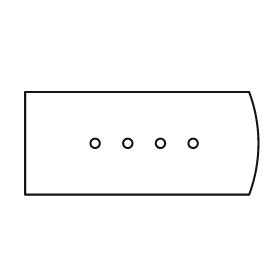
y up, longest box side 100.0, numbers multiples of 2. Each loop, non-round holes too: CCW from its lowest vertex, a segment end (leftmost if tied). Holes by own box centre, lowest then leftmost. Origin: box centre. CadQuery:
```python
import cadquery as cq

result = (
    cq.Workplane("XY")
    .moveTo(-50.0, -22.0)
    .lineTo(46.0, -22.0)
    .threePointArc((50.0, 0.0), (46.0, 22.0))
    .lineTo(-50.0, 22.0)
    .close()
    .moveTo(-20.0, 0.0)
    .circle(2.0)
    .moveTo(-6.0, 0.0)
    .circle(2.0)
    .moveTo(8.0, 0.0)
    .circle(2.0)
    .moveTo(22.0, 0.0)
    .circle(2.0)
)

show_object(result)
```